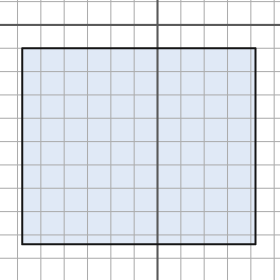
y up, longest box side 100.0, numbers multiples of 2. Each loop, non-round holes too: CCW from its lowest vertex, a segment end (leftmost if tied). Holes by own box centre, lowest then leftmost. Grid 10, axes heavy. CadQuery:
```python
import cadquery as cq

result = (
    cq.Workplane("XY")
    .moveTo(-58.0, -94.0)
    .lineTo(42.0, -94.0)
    .lineTo(42.0, -10.0)
    .lineTo(-58.0, -10.0)
    .close()
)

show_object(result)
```